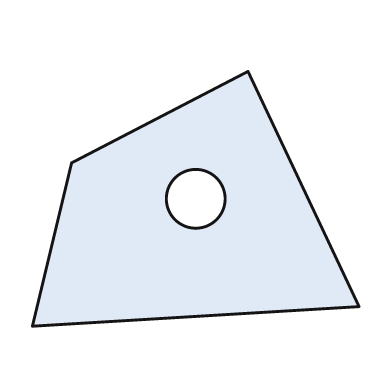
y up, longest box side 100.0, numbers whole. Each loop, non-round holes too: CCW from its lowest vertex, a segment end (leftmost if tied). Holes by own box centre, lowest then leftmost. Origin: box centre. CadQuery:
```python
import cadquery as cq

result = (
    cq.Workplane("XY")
    .moveTo(-50.0, -39.0)
    .lineTo(50.0, -33.0)
    .lineTo(16.0, 39.0)
    .lineTo(-38.0, 11.0)
    .close()
    .moveTo(0.0, 0.0)
    .circle(9.0)
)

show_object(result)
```